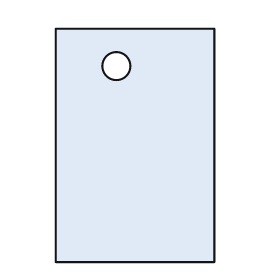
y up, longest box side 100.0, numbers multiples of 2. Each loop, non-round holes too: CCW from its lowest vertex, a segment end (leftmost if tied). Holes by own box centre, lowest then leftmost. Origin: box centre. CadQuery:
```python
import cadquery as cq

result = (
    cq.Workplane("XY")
    .moveTo(-34.0, -50.0)
    .lineTo(34.0, -50.0)
    .lineTo(34.0, 50.0)
    .lineTo(-34.0, 50.0)
    .close()
    .moveTo(-8.0, 34.0)
    .circle(6.0)
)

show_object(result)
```